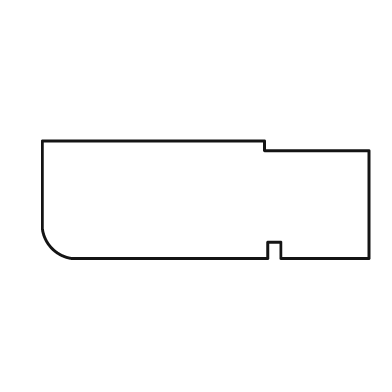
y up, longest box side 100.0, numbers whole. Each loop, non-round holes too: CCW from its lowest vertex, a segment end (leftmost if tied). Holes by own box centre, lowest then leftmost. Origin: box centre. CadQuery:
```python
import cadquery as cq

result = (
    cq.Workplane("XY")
    .moveTo(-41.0, -18.0)
    .lineTo(19.0, -18.0)
    .lineTo(19.0, -13.0)
    .lineTo(23.0, -13.0)
    .lineTo(23.0, -18.0)
    .lineTo(50.0, -18.0)
    .lineTo(50.0, 15.0)
    .lineTo(18.0, 15.0)
    .lineTo(18.0, 18.0)
    .lineTo(-50.0, 18.0)
    .lineTo(-50.0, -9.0)
    .threePointArc((-47.0, -15.0), (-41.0, -18.0))
    .close()
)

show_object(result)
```